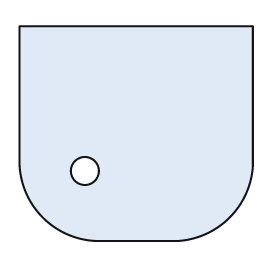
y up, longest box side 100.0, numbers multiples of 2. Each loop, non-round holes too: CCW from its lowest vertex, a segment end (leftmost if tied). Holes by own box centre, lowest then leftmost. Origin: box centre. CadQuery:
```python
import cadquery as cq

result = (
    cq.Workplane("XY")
    .moveTo(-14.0, -46.0)
    .lineTo(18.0, -46.0)
    .threePointArc((40.0, -36.0), (50.0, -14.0))
    .lineTo(50.0, 46.0)
    .lineTo(-50.0, 46.0)
    .lineTo(-50.0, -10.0)
    .threePointArc((-40.0, -36.0), (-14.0, -46.0))
    .close()
    .moveTo(-22.0, -16.0)
    .circle(6.0)
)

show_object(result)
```